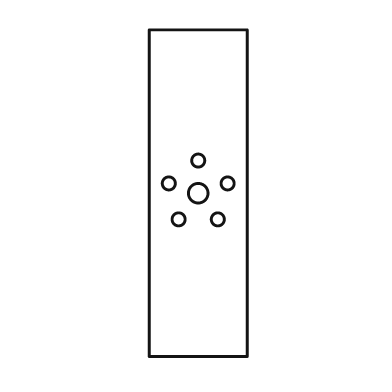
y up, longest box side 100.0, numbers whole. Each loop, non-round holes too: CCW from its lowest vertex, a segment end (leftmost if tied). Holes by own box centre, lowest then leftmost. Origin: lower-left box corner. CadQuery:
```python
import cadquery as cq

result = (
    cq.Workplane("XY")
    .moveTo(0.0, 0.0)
    .lineTo(30.0, 0.0)
    .lineTo(30.0, 100.0)
    .lineTo(0.0, 100.0)
    .close()
    .moveTo(9.0, 42.0)
    .circle(2.0)
    .moveTo(21.0, 42.0)
    .circle(2.0)
    .moveTo(15.0, 50.0)
    .circle(3.0)
    .moveTo(6.0, 53.0)
    .circle(2.0)
    .moveTo(24.0, 53.0)
    .circle(2.0)
    .moveTo(15.0, 60.0)
    .circle(2.0)
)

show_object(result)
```